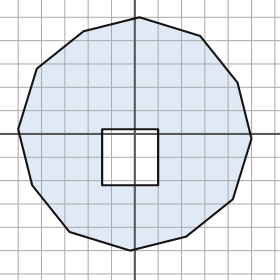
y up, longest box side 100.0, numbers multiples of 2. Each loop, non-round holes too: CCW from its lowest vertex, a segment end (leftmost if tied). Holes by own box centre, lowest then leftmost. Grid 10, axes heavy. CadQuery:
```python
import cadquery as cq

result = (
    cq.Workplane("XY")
    .moveTo(-2.0, -50.0)
    .lineTo(22.0, -44.0)
    .lineTo(42.0, -28.0)
    .lineTo(50.0, -2.0)
    .lineTo(44.0, 22.0)
    .lineTo(28.0, 42.0)
    .lineTo(2.0, 50.0)
    .lineTo(-22.0, 44.0)
    .lineTo(-42.0, 28.0)
    .lineTo(-50.0, 2.0)
    .lineTo(-44.0, -22.0)
    .lineTo(-28.0, -42.0)
    .close()
    .moveTo(-14.0, -22.0)
    .lineTo(10.0, -22.0)
    .lineTo(10.0, 2.0)
    .lineTo(-14.0, 2.0)
    .close()
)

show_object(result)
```